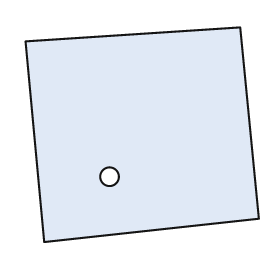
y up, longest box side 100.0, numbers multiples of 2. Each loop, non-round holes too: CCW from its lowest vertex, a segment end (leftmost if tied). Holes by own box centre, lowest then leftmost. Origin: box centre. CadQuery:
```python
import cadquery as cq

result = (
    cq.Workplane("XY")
    .moveTo(-42.0, -46.0)
    .lineTo(50.0, -36.0)
    .lineTo(42.0, 46.0)
    .lineTo(-50.0, 40.0)
    .close()
    .moveTo(-14.0, -18.0)
    .circle(4.0)
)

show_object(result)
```